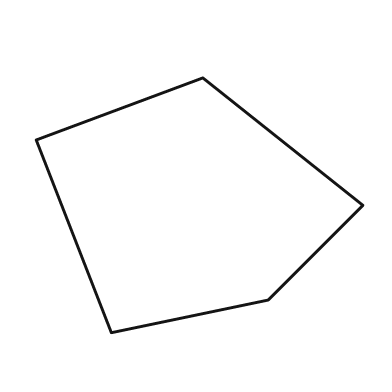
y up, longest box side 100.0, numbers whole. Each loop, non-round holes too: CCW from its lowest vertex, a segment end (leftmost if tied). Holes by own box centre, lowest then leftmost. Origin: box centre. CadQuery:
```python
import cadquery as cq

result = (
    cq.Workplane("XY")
    .moveTo(-27.0, -39.0)
    .lineTo(21.0, -29.0)
    .lineTo(50.0, 0.0)
    .lineTo(1.0, 39.0)
    .lineTo(-50.0, 20.0)
    .close()
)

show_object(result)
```